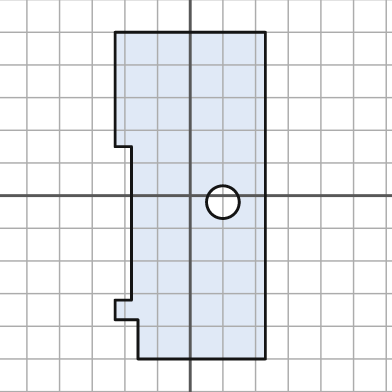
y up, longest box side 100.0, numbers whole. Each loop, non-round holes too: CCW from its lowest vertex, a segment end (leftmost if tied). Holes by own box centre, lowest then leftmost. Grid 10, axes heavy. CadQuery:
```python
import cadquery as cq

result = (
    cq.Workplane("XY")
    .moveTo(-16.0, -50.0)
    .lineTo(23.0, -50.0)
    .lineTo(23.0, 50.0)
    .lineTo(-23.0, 50.0)
    .lineTo(-23.0, 15.0)
    .lineTo(-18.0, 15.0)
    .lineTo(-18.0, -32.0)
    .lineTo(-23.0, -32.0)
    .lineTo(-23.0, -38.0)
    .lineTo(-16.0, -38.0)
    .close()
    .moveTo(10.0, -2.0)
    .circle(5.0)
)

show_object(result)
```